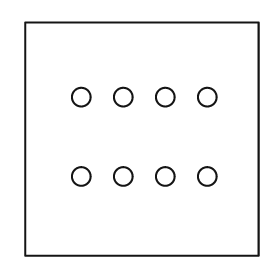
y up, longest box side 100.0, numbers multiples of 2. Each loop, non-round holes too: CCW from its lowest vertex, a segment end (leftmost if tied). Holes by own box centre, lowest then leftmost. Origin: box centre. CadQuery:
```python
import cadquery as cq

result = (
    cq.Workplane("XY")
    .moveTo(-50.0, -50.0)
    .lineTo(50.0, -50.0)
    .lineTo(50.0, 50.0)
    .lineTo(-50.0, 50.0)
    .close()
    .moveTo(-26.0, -16.0)
    .circle(4.0)
    .moveTo(-8.0, -16.0)
    .circle(4.0)
    .moveTo(10.0, -16.0)
    .circle(4.0)
    .moveTo(28.0, -16.0)
    .circle(4.0)
    .moveTo(-26.0, 18.0)
    .circle(4.0)
    .moveTo(-8.0, 18.0)
    .circle(4.0)
    .moveTo(10.0, 18.0)
    .circle(4.0)
    .moveTo(28.0, 18.0)
    .circle(4.0)
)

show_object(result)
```